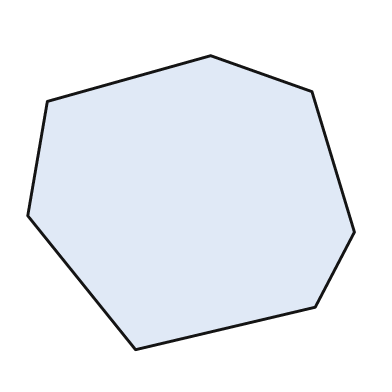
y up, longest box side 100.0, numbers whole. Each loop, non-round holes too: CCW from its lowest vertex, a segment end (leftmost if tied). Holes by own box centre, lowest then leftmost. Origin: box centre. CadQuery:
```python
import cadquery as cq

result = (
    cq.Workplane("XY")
    .moveTo(-17.0, -45.0)
    .lineTo(38.0, -32.0)
    .lineTo(50.0, -9.0)
    .lineTo(37.0, 34.0)
    .lineTo(6.0, 45.0)
    .lineTo(-44.0, 31.0)
    .lineTo(-50.0, -4.0)
    .close()
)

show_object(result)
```